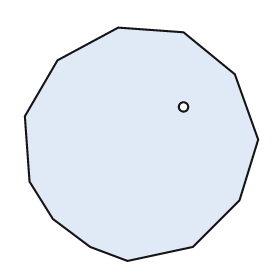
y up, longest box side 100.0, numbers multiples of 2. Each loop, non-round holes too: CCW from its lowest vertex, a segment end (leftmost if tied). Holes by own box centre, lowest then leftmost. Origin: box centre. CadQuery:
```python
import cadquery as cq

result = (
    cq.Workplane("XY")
    .moveTo(-6.0, -50.0)
    .lineTo(22.0, -44.0)
    .lineTo(42.0, -24.0)
    .lineTo(50.0, 2.0)
    .lineTo(40.0, 30.0)
    .lineTo(18.0, 48.0)
    .lineTo(-10.0, 50.0)
    .lineTo(-36.0, 36.0)
    .lineTo(-50.0, 12.0)
    .lineTo(-48.0, -16.0)
    .lineTo(-38.0, -32.0)
    .lineTo(-22.0, -44.0)
    .close()
    .moveTo(18.0, 16.0)
    .circle(2.0)
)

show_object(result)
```